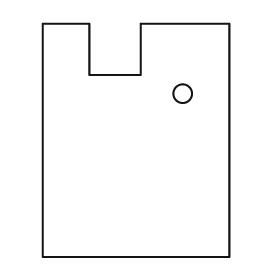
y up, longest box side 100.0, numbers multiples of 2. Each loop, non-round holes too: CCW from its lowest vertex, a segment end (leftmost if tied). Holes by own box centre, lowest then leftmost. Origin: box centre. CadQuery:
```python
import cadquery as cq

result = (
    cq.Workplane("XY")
    .moveTo(-40.0, -50.0)
    .lineTo(40.0, -50.0)
    .lineTo(40.0, 50.0)
    .lineTo(2.0, 50.0)
    .lineTo(2.0, 28.0)
    .lineTo(-20.0, 28.0)
    .lineTo(-20.0, 50.0)
    .lineTo(-40.0, 50.0)
    .close()
    .moveTo(20.0, 20.0)
    .circle(4.0)
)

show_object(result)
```